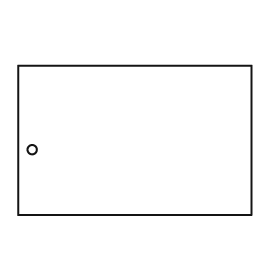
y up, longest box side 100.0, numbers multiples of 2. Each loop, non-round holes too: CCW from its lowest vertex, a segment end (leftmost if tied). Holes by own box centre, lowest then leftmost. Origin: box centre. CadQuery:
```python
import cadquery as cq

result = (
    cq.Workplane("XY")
    .moveTo(-50.0, -32.0)
    .lineTo(50.0, -32.0)
    .lineTo(50.0, 32.0)
    .lineTo(-50.0, 32.0)
    .close()
    .moveTo(-44.0, -4.0)
    .circle(2.0)
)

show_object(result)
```